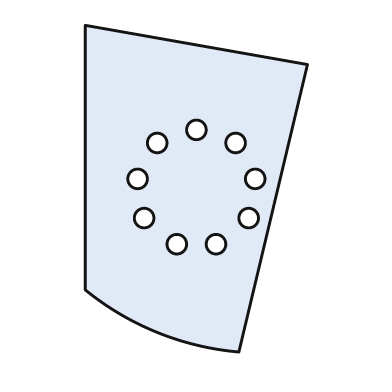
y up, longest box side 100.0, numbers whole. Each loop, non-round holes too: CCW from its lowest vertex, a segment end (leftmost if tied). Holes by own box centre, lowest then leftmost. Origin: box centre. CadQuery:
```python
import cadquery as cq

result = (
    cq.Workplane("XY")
    .moveTo(13.0, -50.0)
    .lineTo(34.0, 38.0)
    .lineTo(-34.0, 50.0)
    .lineTo(-34.0, -31.0)
    .threePointArc((-12.0, -44.0), (13.0, -50.0))
    .close()
    .moveTo(-6.0, -17.0)
    .circle(3.0)
    .moveTo(6.0, -17.0)
    .circle(3.0)
    .moveTo(-16.0, -9.0)
    .circle(3.0)
    .moveTo(16.0, -9.0)
    .circle(3.0)
    .moveTo(-18.0, 3.0)
    .circle(3.0)
    .moveTo(18.0, 3.0)
    .circle(3.0)
    .moveTo(-12.0, 14.0)
    .circle(3.0)
    .moveTo(12.0, 14.0)
    .circle(3.0)
    .moveTo(0.0, 18.0)
    .circle(3.0)
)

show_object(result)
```